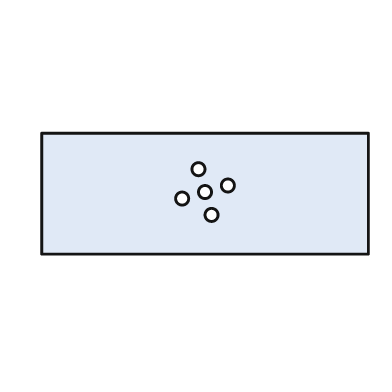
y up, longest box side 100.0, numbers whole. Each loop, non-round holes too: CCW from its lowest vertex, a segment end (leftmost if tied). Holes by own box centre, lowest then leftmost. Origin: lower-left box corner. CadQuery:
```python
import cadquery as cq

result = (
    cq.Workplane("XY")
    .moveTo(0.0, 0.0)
    .lineTo(100.0, 0.0)
    .lineTo(100.0, 37.0)
    .lineTo(0.0, 37.0)
    .close()
    .moveTo(52.0, 12.0)
    .circle(2.0)
    .moveTo(43.0, 17.0)
    .circle(2.0)
    .moveTo(50.0, 19.0)
    .circle(2.0)
    .moveTo(57.0, 21.0)
    .circle(2.0)
    .moveTo(48.0, 26.0)
    .circle(2.0)
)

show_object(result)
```